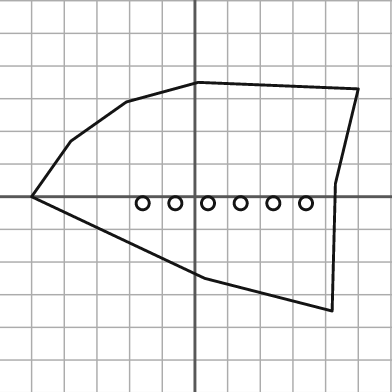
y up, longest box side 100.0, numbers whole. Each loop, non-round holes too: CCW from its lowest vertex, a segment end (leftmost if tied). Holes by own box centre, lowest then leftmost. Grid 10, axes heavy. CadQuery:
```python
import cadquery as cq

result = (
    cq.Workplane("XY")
    .moveTo(42.0, -35.0)
    .lineTo(43.0, 4.0)
    .lineTo(50.0, 33.0)
    .lineTo(1.0, 35.0)
    .lineTo(-21.0, 29.0)
    .lineTo(-38.0, 17.0)
    .lineTo(-50.0, 0.0)
    .lineTo(3.0, -25.0)
    .close()
    .moveTo(-16.0, -2.0)
    .circle(2.0)
    .moveTo(-6.0, -2.0)
    .circle(2.0)
    .moveTo(4.0, -2.0)
    .circle(2.0)
    .moveTo(14.0, -2.0)
    .circle(2.0)
    .moveTo(24.0, -2.0)
    .circle(2.0)
    .moveTo(34.0, -2.0)
    .circle(2.0)
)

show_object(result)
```